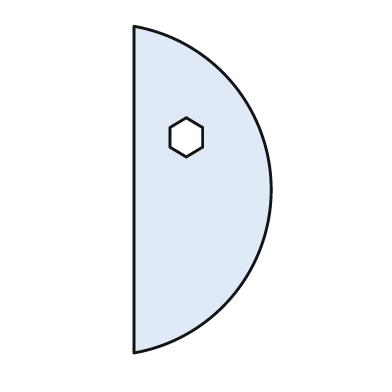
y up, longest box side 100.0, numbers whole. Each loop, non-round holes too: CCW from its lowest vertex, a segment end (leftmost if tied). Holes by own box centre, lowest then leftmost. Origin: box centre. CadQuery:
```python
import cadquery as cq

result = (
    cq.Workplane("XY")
    .moveTo(-21.0, -50.0)
    .threePointArc((21.0, 0.0), (-21.0, 50.0))
    .close()
    .moveTo(-5.0, 10.0)
    .lineTo(0.0, 13.0)
    .lineTo(0.0, 19.0)
    .lineTo(-5.0, 22.0)
    .lineTo(-10.0, 19.0)
    .lineTo(-10.0, 13.0)
    .close()
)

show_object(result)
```